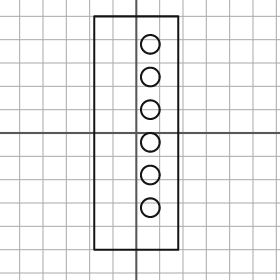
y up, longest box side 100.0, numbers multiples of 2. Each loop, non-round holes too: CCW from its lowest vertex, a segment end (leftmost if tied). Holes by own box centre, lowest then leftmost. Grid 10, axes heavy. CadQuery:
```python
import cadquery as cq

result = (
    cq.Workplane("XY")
    .moveTo(-18.0, -50.0)
    .lineTo(18.0, -50.0)
    .lineTo(18.0, 50.0)
    .lineTo(-18.0, 50.0)
    .close()
    .moveTo(6.0, -32.0)
    .circle(4.0)
    .moveTo(6.0, -18.0)
    .circle(4.0)
    .moveTo(6.0, -4.0)
    .circle(4.0)
    .moveTo(6.0, 10.0)
    .circle(4.0)
    .moveTo(6.0, 24.0)
    .circle(4.0)
    .moveTo(6.0, 38.0)
    .circle(4.0)
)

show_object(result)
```